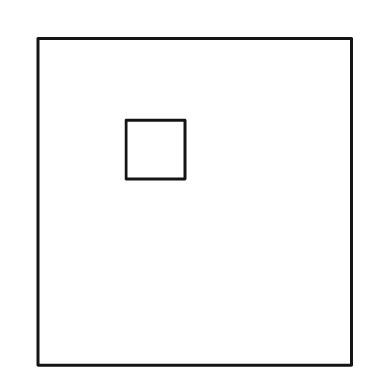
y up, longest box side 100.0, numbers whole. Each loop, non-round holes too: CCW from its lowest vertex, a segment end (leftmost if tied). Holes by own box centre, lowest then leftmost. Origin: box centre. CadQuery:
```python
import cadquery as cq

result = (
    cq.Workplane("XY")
    .moveTo(-48.0, -50.0)
    .lineTo(48.0, -50.0)
    .lineTo(48.0, 50.0)
    .lineTo(-48.0, 50.0)
    .close()
    .moveTo(-21.0, 7.0)
    .lineTo(-3.0, 7.0)
    .lineTo(-3.0, 25.0)
    .lineTo(-21.0, 25.0)
    .close()
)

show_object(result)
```